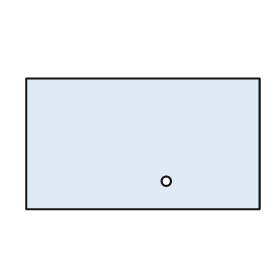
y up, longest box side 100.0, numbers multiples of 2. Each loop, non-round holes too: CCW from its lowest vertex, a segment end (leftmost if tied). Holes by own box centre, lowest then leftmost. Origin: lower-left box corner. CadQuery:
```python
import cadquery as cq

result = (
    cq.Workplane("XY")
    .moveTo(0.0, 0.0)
    .lineTo(100.0, 0.0)
    .lineTo(100.0, 56.0)
    .lineTo(0.0, 56.0)
    .close()
    .moveTo(60.0, 12.0)
    .circle(2.0)
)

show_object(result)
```